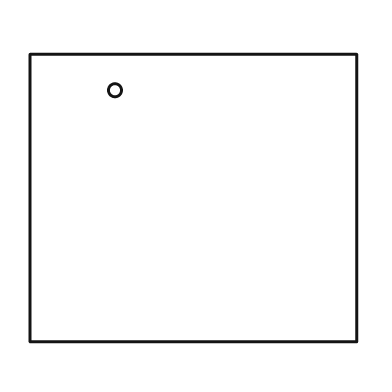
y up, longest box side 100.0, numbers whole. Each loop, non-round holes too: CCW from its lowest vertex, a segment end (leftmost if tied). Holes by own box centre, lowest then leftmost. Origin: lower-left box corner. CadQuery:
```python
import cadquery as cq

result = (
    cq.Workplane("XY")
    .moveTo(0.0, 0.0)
    .lineTo(100.0, 0.0)
    .lineTo(100.0, 88.0)
    .lineTo(0.0, 88.0)
    .close()
    .moveTo(26.0, 77.0)
    .circle(2.0)
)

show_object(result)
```